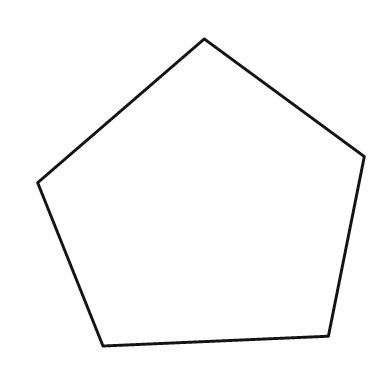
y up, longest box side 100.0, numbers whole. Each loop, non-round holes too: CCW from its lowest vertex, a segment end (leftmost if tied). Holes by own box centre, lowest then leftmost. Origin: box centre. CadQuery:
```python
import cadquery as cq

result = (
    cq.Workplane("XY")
    .moveTo(-30.0, -47.0)
    .lineTo(39.0, -44.0)
    .lineTo(50.0, 11.0)
    .lineTo(1.0, 47.0)
    .lineTo(-50.0, 3.0)
    .close()
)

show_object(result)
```